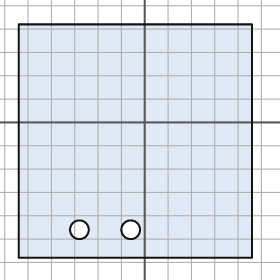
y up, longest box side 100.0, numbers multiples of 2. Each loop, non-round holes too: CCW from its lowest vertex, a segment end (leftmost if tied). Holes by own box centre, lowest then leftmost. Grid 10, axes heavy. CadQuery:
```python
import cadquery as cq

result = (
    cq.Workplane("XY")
    .moveTo(-54.0, -58.0)
    .lineTo(46.0, -58.0)
    .lineTo(46.0, 42.0)
    .lineTo(-54.0, 42.0)
    .close()
    .moveTo(-28.0, -46.0)
    .circle(4.0)
    .moveTo(-6.0, -46.0)
    .circle(4.0)
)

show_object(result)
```